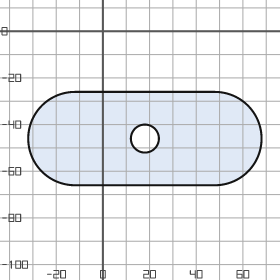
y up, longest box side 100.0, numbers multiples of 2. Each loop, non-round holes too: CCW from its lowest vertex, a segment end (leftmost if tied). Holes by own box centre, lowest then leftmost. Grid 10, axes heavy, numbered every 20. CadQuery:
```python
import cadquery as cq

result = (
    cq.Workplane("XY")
    .moveTo(-12.0, -66.0)
    .lineTo(48.0, -66.0)
    .threePointArc((68.0, -46.0), (48.0, -26.0))
    .lineTo(-12.0, -26.0)
    .threePointArc((-32.0, -46.0), (-12.0, -66.0))
    .close()
    .moveTo(18.0, -46.0)
    .circle(6.0)
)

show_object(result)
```